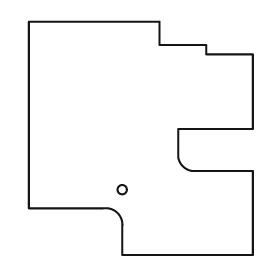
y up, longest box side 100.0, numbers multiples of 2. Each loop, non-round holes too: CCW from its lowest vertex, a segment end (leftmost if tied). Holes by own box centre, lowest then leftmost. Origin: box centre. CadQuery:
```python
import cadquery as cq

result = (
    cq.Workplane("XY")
    .moveTo(-8.0, -50.0)
    .lineTo(48.0, -50.0)
    .lineTo(48.0, -14.0)
    .lineTo(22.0, -14.0)
    .threePointArc((18.0, -12.0), (16.0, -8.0))
    .lineTo(16.0, 4.0)
    .lineTo(48.0, 4.0)
    .lineTo(48.0, 36.0)
    .lineTo(28.0, 36.0)
    .lineTo(28.0, 40.0)
    .lineTo(8.0, 40.0)
    .lineTo(8.0, 50.0)
    .lineTo(-48.0, 50.0)
    .lineTo(-48.0, -30.0)
    .lineTo(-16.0, -30.0)
    .threePointArc((-10.0, -32.0), (-8.0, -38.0))
    .close()
    .moveTo(-8.0, -22.0)
    .circle(2.0)
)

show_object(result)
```